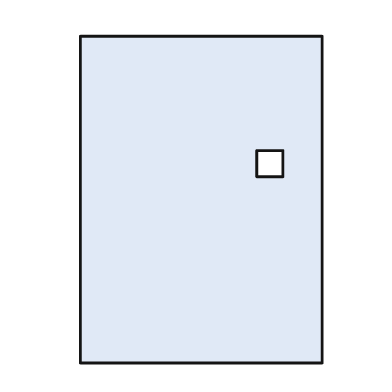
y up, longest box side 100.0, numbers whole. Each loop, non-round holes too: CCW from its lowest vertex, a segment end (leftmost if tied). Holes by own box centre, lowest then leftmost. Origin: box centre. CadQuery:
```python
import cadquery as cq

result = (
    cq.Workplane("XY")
    .moveTo(-37.0, -50.0)
    .lineTo(37.0, -50.0)
    .lineTo(37.0, 50.0)
    .lineTo(-37.0, 50.0)
    .close()
    .moveTo(17.0, 7.0)
    .lineTo(25.0, 7.0)
    .lineTo(25.0, 15.0)
    .lineTo(17.0, 15.0)
    .close()
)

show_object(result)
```